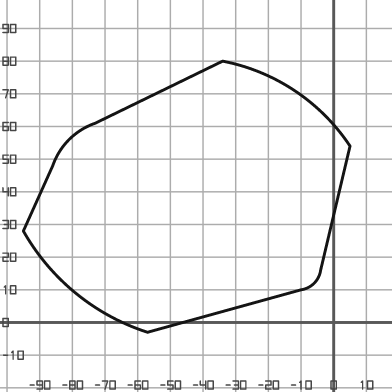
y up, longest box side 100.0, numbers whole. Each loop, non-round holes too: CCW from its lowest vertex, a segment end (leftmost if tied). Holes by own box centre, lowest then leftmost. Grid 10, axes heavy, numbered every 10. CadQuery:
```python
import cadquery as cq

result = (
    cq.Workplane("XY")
    .moveTo(-57.0, -3.0)
    .lineTo(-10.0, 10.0)
    .threePointArc((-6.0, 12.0), (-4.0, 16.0))
    .lineTo(5.0, 54.0)
    .threePointArc((-12.0, 71.0), (-34.0, 80.0))
    .lineTo(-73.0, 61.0)
    .threePointArc((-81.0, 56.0), (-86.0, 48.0))
    .lineTo(-95.0, 28.0)
    .threePointArc((-79.0, 9.0), (-57.0, -3.0))
    .close()
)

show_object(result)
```